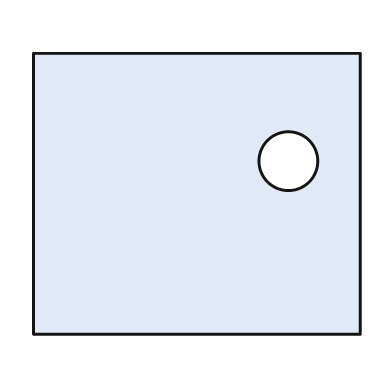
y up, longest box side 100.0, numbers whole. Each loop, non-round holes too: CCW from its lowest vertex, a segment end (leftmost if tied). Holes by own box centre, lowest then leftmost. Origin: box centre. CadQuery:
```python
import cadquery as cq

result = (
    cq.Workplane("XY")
    .moveTo(-50.0, -43.0)
    .lineTo(50.0, -43.0)
    .lineTo(50.0, 43.0)
    .lineTo(-50.0, 43.0)
    .close()
    .moveTo(28.0, 10.0)
    .circle(9.0)
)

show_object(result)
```